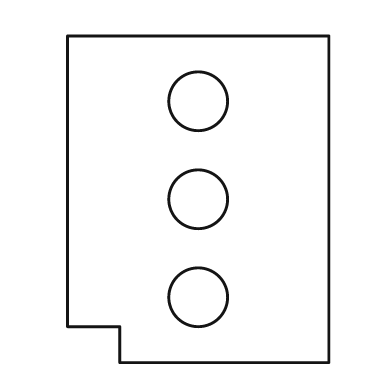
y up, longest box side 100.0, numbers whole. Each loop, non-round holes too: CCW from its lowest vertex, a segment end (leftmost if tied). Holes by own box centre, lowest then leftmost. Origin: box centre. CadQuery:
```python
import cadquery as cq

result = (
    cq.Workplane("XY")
    .moveTo(-24.0, -50.0)
    .lineTo(40.0, -50.0)
    .lineTo(40.0, 50.0)
    .lineTo(-40.0, 50.0)
    .lineTo(-40.0, -39.0)
    .lineTo(-24.0, -39.0)
    .close()
    .moveTo(0.0, -30.0)
    .circle(9.0)
    .moveTo(0.0, 0.0)
    .circle(9.0)
    .moveTo(0.0, 30.0)
    .circle(9.0)
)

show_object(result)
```